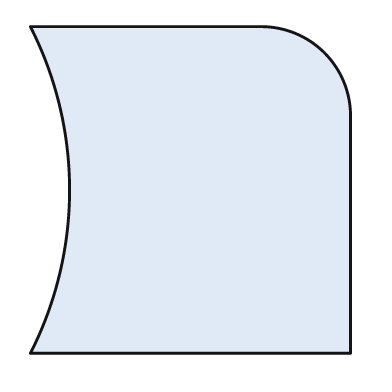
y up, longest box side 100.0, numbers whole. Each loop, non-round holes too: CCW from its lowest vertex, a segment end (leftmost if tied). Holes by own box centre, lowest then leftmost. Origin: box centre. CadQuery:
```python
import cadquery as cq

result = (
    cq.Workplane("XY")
    .moveTo(-49.0, -50.0)
    .lineTo(49.0, -50.0)
    .lineTo(49.0, 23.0)
    .threePointArc((41.0, 42.0), (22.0, 50.0))
    .lineTo(-49.0, 50.0)
    .threePointArc((-37.0, 0.0), (-49.0, -50.0))
    .close()
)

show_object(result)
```